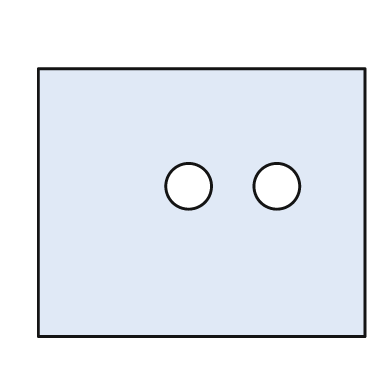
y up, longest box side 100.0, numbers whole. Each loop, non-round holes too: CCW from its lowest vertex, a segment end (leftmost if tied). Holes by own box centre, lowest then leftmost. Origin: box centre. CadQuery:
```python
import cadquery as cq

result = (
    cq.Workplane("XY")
    .moveTo(-50.0, -41.0)
    .lineTo(50.0, -41.0)
    .lineTo(50.0, 41.0)
    .lineTo(-50.0, 41.0)
    .close()
    .moveTo(-4.0, 5.0)
    .circle(7.0)
    .moveTo(23.0, 5.0)
    .circle(7.0)
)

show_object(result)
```